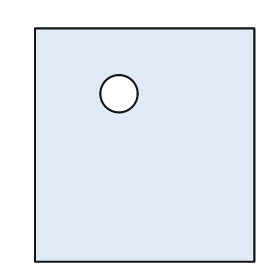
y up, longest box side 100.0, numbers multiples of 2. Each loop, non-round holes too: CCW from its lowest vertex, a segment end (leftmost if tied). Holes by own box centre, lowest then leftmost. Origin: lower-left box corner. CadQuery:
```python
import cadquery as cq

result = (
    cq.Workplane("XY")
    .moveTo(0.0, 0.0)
    .lineTo(94.0, 0.0)
    .lineTo(94.0, 100.0)
    .lineTo(0.0, 100.0)
    .close()
    .moveTo(36.0, 72.0)
    .circle(8.0)
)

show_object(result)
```